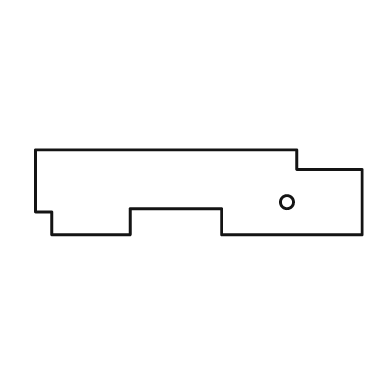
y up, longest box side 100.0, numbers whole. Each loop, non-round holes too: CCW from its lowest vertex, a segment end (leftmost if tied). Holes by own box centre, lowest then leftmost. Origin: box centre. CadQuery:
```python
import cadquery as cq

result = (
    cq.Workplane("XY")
    .moveTo(-45.0, -13.0)
    .lineTo(-21.0, -13.0)
    .lineTo(-21.0, -5.0)
    .lineTo(7.0, -5.0)
    .lineTo(7.0, -13.0)
    .lineTo(50.0, -13.0)
    .lineTo(50.0, 7.0)
    .lineTo(30.0, 7.0)
    .lineTo(30.0, 13.0)
    .lineTo(-50.0, 13.0)
    .lineTo(-50.0, -6.0)
    .lineTo(-45.0, -6.0)
    .close()
    .moveTo(27.0, -3.0)
    .circle(2.0)
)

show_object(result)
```